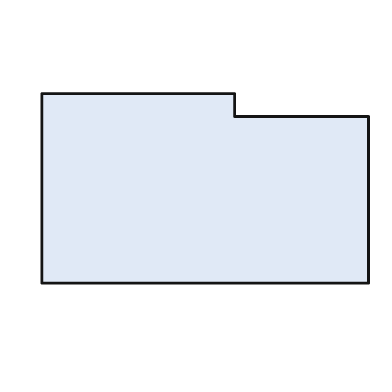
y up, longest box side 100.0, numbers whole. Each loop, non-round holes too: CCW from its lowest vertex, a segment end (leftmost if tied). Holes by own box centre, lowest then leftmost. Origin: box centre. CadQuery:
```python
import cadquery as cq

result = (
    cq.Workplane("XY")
    .moveTo(-50.0, -29.0)
    .lineTo(50.0, -29.0)
    .lineTo(50.0, 22.0)
    .lineTo(9.0, 22.0)
    .lineTo(9.0, 29.0)
    .lineTo(-50.0, 29.0)
    .close()
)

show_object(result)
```